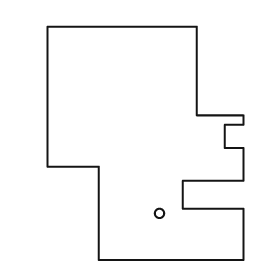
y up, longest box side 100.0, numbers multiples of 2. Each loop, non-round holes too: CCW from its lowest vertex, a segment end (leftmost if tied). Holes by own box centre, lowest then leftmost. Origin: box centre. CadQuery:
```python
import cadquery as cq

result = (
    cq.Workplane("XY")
    .moveTo(-20.0, -50.0)
    .lineTo(42.0, -50.0)
    .lineTo(42.0, -28.0)
    .lineTo(16.0, -28.0)
    .lineTo(16.0, -16.0)
    .lineTo(42.0, -16.0)
    .lineTo(42.0, -2.0)
    .lineTo(34.0, -2.0)
    .lineTo(34.0, 8.0)
    .lineTo(42.0, 8.0)
    .lineTo(42.0, 12.0)
    .lineTo(22.0, 12.0)
    .lineTo(22.0, 50.0)
    .lineTo(-42.0, 50.0)
    .lineTo(-42.0, -10.0)
    .lineTo(-20.0, -10.0)
    .close()
    .moveTo(6.0, -30.0)
    .circle(2.0)
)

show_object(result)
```